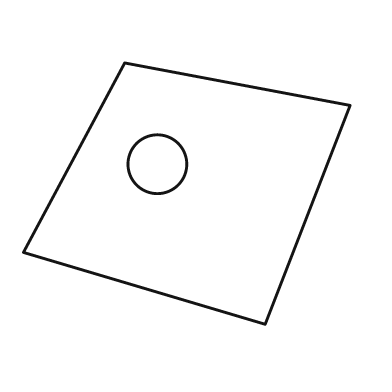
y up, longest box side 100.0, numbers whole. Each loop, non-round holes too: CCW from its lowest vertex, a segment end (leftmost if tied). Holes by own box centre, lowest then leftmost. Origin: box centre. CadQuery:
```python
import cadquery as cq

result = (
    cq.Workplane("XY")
    .moveTo(24.0, -40.0)
    .lineTo(50.0, 27.0)
    .lineTo(-19.0, 40.0)
    .lineTo(-50.0, -18.0)
    .close()
    .moveTo(-9.0, 9.0)
    .circle(9.0)
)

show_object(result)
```